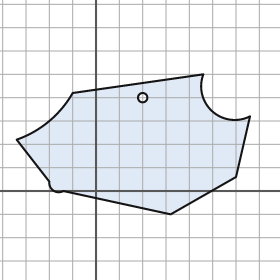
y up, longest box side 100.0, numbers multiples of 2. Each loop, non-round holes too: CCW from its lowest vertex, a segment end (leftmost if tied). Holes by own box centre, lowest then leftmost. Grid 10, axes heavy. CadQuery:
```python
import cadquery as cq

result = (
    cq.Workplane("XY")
    .moveTo(32.0, -10.0)
    .lineTo(60.0, 6.0)
    .lineTo(66.0, 32.0)
    .threePointArc((50.0, 34.0), (46.0, 50.0))
    .lineTo(-10.0, 42.0)
    .threePointArc((-20.0, 30.0), (-34.0, 22.0))
    .lineTo(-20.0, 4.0)
    .threePointArc((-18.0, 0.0), (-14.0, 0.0))
    .close()
    .moveTo(20.0, 40.0)
    .circle(2.0)
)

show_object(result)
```